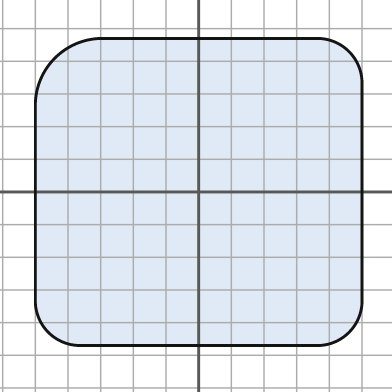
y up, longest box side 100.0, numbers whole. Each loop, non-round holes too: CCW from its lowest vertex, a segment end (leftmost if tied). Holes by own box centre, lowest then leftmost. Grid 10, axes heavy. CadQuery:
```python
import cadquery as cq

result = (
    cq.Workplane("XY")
    .moveTo(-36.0, -47.0)
    .lineTo(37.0, -47.0)
    .threePointArc((46.0, -43.0), (50.0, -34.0))
    .lineTo(50.0, 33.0)
    .threePointArc((46.0, 43.0), (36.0, 47.0))
    .lineTo(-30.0, 47.0)
    .threePointArc((-44.0, 41.0), (-50.0, 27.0))
    .lineTo(-50.0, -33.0)
    .threePointArc((-46.0, -43.0), (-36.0, -47.0))
    .close()
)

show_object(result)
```